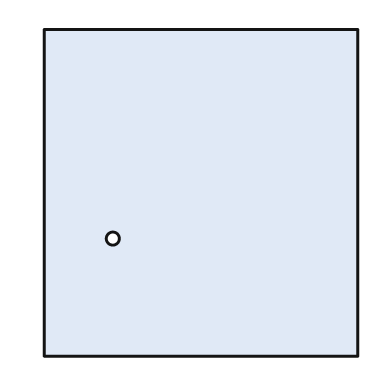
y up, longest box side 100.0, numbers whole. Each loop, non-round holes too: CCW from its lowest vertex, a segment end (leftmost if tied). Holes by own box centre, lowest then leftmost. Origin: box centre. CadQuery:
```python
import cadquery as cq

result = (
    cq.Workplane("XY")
    .moveTo(-48.0, -50.0)
    .lineTo(48.0, -50.0)
    .lineTo(48.0, 50.0)
    .lineTo(-48.0, 50.0)
    .close()
    .moveTo(-27.0, -14.0)
    .circle(2.0)
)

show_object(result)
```